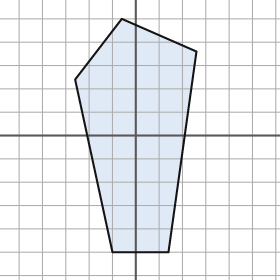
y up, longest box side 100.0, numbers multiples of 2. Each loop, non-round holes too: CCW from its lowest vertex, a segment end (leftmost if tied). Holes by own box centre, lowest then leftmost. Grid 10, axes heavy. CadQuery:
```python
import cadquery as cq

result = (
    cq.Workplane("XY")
    .moveTo(-10.0, -50.0)
    .lineTo(14.0, -50.0)
    .lineTo(26.0, 36.0)
    .lineTo(-6.0, 50.0)
    .lineTo(-26.0, 24.0)
    .close()
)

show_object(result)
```